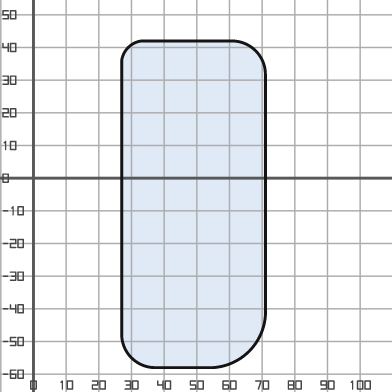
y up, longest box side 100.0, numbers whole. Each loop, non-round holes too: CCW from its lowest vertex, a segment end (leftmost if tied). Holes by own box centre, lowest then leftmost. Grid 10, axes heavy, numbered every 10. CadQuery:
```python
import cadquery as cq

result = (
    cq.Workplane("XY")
    .moveTo(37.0, -58.0)
    .lineTo(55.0, -58.0)
    .threePointArc((66.0, -53.0), (71.0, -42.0))
    .lineTo(71.0, 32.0)
    .threePointArc((68.0, 39.0), (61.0, 42.0))
    .lineTo(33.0, 42.0)
    .threePointArc((29.0, 40.0), (27.0, 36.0))
    .lineTo(27.0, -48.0)
    .threePointArc((30.0, -55.0), (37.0, -58.0))
    .close()
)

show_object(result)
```